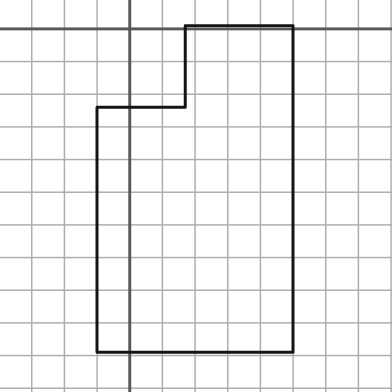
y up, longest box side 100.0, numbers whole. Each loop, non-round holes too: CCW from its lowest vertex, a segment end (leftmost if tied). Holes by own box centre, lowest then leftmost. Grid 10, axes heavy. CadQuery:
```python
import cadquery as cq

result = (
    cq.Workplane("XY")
    .moveTo(-10.0, -99.0)
    .lineTo(50.0, -99.0)
    .lineTo(50.0, 1.0)
    .lineTo(17.0, 1.0)
    .lineTo(17.0, -24.0)
    .lineTo(-10.0, -24.0)
    .close()
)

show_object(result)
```